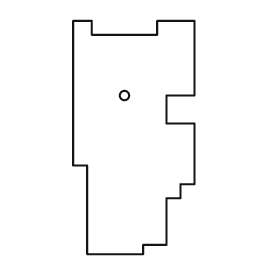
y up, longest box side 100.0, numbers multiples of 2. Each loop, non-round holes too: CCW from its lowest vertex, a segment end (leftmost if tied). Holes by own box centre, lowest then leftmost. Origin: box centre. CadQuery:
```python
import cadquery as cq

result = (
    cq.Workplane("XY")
    .moveTo(-20.0, -50.0)
    .lineTo(4.0, -50.0)
    .lineTo(4.0, -46.0)
    .lineTo(14.0, -46.0)
    .lineTo(14.0, -26.0)
    .lineTo(20.0, -26.0)
    .lineTo(20.0, -20.0)
    .lineTo(26.0, -20.0)
    .lineTo(26.0, 6.0)
    .lineTo(14.0, 6.0)
    .lineTo(14.0, 18.0)
    .lineTo(26.0, 18.0)
    .lineTo(26.0, 50.0)
    .lineTo(10.0, 50.0)
    .lineTo(10.0, 44.0)
    .lineTo(-18.0, 44.0)
    .lineTo(-18.0, 50.0)
    .lineTo(-26.0, 50.0)
    .lineTo(-26.0, -12.0)
    .lineTo(-20.0, -12.0)
    .close()
    .moveTo(-4.0, 18.0)
    .circle(2.0)
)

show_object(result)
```